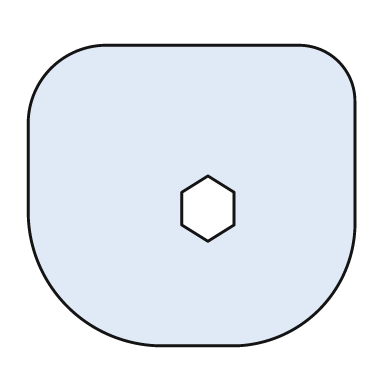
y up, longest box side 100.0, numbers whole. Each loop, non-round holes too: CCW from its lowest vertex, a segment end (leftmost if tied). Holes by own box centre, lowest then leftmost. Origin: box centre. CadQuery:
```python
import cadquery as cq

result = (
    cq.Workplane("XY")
    .moveTo(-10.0, -46.0)
    .lineTo(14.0, -46.0)
    .threePointArc((39.0, -35.0), (50.0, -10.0))
    .lineTo(50.0, 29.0)
    .threePointArc((45.0, 41.0), (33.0, 46.0))
    .lineTo(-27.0, 46.0)
    .threePointArc((-43.0, 39.0), (-50.0, 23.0))
    .lineTo(-50.0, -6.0)
    .threePointArc((-38.0, -34.0), (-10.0, -46.0))
    .close()
    .moveTo(5.0, -14.0)
    .lineTo(13.0, -9.0)
    .lineTo(13.0, 1.0)
    .lineTo(5.0, 6.0)
    .lineTo(-3.0, 1.0)
    .lineTo(-3.0, -9.0)
    .close()
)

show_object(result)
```